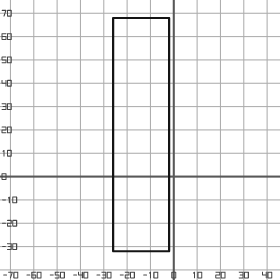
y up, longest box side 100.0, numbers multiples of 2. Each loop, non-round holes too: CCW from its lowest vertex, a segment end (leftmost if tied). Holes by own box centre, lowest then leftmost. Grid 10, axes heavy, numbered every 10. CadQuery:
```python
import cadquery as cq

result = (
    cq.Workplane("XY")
    .moveTo(-26.0, -32.0)
    .lineTo(-2.0, -32.0)
    .lineTo(-2.0, 68.0)
    .lineTo(-26.0, 68.0)
    .close()
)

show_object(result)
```